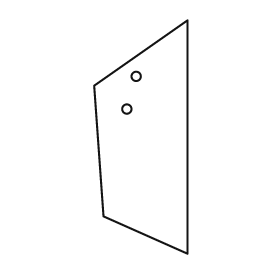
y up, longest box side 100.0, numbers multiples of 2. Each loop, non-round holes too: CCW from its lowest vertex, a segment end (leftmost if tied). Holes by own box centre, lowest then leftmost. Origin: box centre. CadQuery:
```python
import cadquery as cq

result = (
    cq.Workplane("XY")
    .moveTo(20.0, -50.0)
    .lineTo(20.0, 50.0)
    .lineTo(-20.0, 22.0)
    .lineTo(-16.0, -34.0)
    .close()
    .moveTo(-6.0, 12.0)
    .circle(2.0)
    .moveTo(-2.0, 26.0)
    .circle(2.0)
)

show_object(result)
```